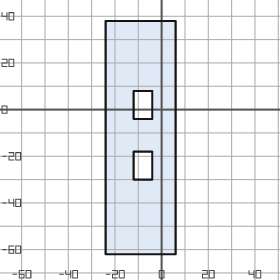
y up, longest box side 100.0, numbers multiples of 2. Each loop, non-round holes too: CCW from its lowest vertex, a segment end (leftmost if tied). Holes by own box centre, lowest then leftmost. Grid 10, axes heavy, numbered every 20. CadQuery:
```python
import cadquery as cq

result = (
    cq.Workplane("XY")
    .moveTo(-24.0, -62.0)
    .lineTo(6.0, -62.0)
    .lineTo(6.0, 38.0)
    .lineTo(-24.0, 38.0)
    .close()
    .moveTo(-12.0, -30.0)
    .lineTo(-4.0, -30.0)
    .lineTo(-4.0, -18.0)
    .lineTo(-12.0, -18.0)
    .close()
    .moveTo(-12.0, -4.0)
    .lineTo(-4.0, -4.0)
    .lineTo(-4.0, 8.0)
    .lineTo(-12.0, 8.0)
    .close()
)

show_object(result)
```